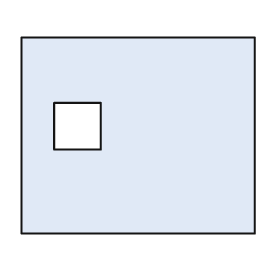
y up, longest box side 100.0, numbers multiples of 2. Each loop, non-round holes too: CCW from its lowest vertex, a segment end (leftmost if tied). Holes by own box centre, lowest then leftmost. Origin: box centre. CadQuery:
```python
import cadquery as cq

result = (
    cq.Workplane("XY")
    .moveTo(-50.0, -42.0)
    .lineTo(50.0, -42.0)
    .lineTo(50.0, 42.0)
    .lineTo(-50.0, 42.0)
    .close()
    .moveTo(-36.0, -6.0)
    .lineTo(-16.0, -6.0)
    .lineTo(-16.0, 14.0)
    .lineTo(-36.0, 14.0)
    .close()
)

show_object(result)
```